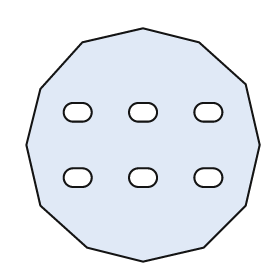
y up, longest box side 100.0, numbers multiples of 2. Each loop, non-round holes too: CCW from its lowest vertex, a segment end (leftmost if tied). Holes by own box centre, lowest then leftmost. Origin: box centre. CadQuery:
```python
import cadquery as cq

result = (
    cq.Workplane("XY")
    .moveTo(0.0, -50.0)
    .lineTo(26.0, -44.0)
    .lineTo(44.0, -26.0)
    .lineTo(50.0, 0.0)
    .lineTo(44.0, 26.0)
    .lineTo(24.0, 44.0)
    .lineTo(0.0, 50.0)
    .lineTo(-26.0, 44.0)
    .lineTo(-44.0, 24.0)
    .lineTo(-50.0, 0.0)
    .lineTo(-44.0, -26.0)
    .lineTo(-24.0, -44.0)
    .close()
    .moveTo(-30.0, -18.0)
    .lineTo(-26.0, -18.0)
    .threePointArc((-22.0, -14.0), (-26.0, -10.0))
    .lineTo(-30.0, -10.0)
    .threePointArc((-34.0, -14.0), (-30.0, -18.0))
    .close()
    .moveTo(-2.0, -18.0)
    .lineTo(2.0, -18.0)
    .threePointArc((6.0, -14.0), (2.0, -10.0))
    .lineTo(-2.0, -10.0)
    .threePointArc((-6.0, -14.0), (-2.0, -18.0))
    .close()
    .moveTo(26.0, -18.0)
    .lineTo(30.0, -18.0)
    .threePointArc((34.0, -14.0), (30.0, -10.0))
    .lineTo(26.0, -10.0)
    .threePointArc((22.0, -14.0), (26.0, -18.0))
    .close()
    .moveTo(-30.0, 10.0)
    .lineTo(-26.0, 10.0)
    .threePointArc((-22.0, 14.0), (-26.0, 18.0))
    .lineTo(-30.0, 18.0)
    .threePointArc((-34.0, 14.0), (-30.0, 10.0))
    .close()
    .moveTo(-2.0, 10.0)
    .lineTo(2.0, 10.0)
    .threePointArc((6.0, 14.0), (2.0, 18.0))
    .lineTo(-2.0, 18.0)
    .threePointArc((-6.0, 14.0), (-2.0, 10.0))
    .close()
    .moveTo(26.0, 10.0)
    .lineTo(30.0, 10.0)
    .threePointArc((34.0, 14.0), (30.0, 18.0))
    .lineTo(26.0, 18.0)
    .threePointArc((22.0, 14.0), (26.0, 10.0))
    .close()
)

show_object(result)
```